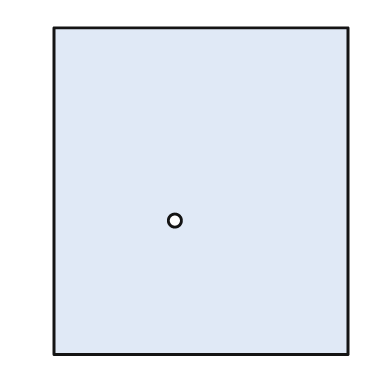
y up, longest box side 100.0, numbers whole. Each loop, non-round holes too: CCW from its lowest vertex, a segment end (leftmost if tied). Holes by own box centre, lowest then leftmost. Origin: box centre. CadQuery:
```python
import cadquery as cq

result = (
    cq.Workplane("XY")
    .moveTo(-45.0, -50.0)
    .lineTo(45.0, -50.0)
    .lineTo(45.0, 50.0)
    .lineTo(-45.0, 50.0)
    .close()
    .moveTo(-8.0, -9.0)
    .circle(2.0)
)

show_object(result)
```